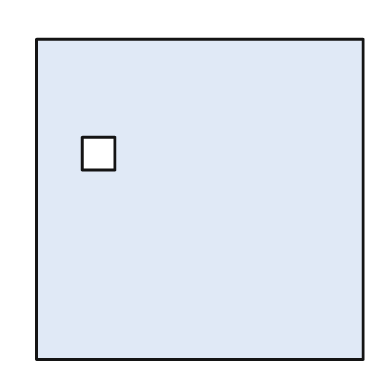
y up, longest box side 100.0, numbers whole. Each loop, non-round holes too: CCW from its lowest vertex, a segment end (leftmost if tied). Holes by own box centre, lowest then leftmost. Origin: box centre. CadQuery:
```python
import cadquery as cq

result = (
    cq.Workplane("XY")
    .moveTo(-50.0, -49.0)
    .lineTo(50.0, -49.0)
    .lineTo(50.0, 49.0)
    .lineTo(-50.0, 49.0)
    .close()
    .moveTo(-36.0, 9.0)
    .lineTo(-26.0, 9.0)
    .lineTo(-26.0, 19.0)
    .lineTo(-36.0, 19.0)
    .close()
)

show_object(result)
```